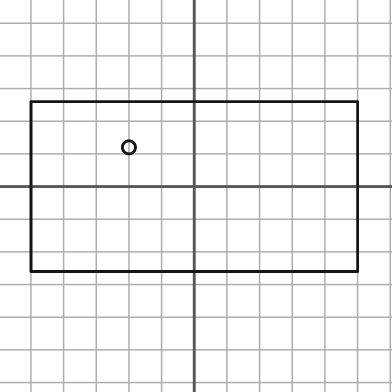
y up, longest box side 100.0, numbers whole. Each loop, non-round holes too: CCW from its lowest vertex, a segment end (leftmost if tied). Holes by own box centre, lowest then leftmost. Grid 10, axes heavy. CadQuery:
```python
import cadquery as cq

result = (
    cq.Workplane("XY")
    .moveTo(-50.0, -26.0)
    .lineTo(50.0, -26.0)
    .lineTo(50.0, 26.0)
    .lineTo(-50.0, 26.0)
    .close()
    .moveTo(-20.0, 12.0)
    .circle(2.0)
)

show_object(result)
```